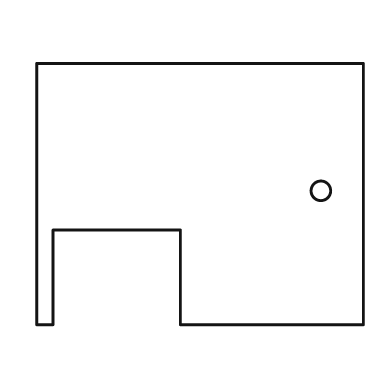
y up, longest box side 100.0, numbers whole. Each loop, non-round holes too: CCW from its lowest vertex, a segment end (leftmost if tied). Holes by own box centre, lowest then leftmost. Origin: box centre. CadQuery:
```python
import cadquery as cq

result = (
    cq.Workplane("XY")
    .moveTo(-50.0, -40.0)
    .lineTo(-45.0, -40.0)
    .lineTo(-45.0, -11.0)
    .lineTo(-6.0, -11.0)
    .lineTo(-6.0, -40.0)
    .lineTo(50.0, -40.0)
    .lineTo(50.0, 40.0)
    .lineTo(-50.0, 40.0)
    .close()
    .moveTo(37.0, 1.0)
    .circle(3.0)
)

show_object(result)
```